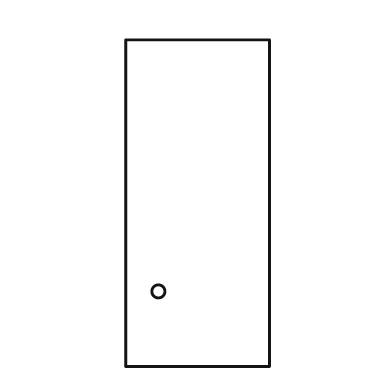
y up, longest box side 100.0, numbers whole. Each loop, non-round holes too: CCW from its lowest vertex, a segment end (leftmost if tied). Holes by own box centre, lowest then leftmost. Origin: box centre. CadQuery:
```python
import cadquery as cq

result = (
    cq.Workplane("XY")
    .moveTo(-22.0, -50.0)
    .lineTo(22.0, -50.0)
    .lineTo(22.0, 50.0)
    .lineTo(-22.0, 50.0)
    .close()
    .moveTo(-12.0, -27.0)
    .circle(2.0)
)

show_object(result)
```